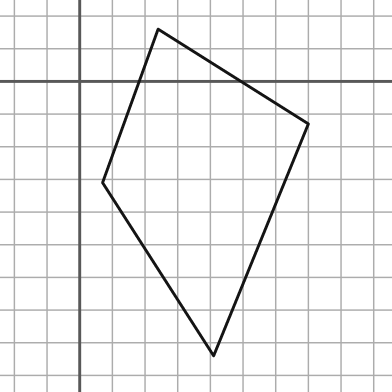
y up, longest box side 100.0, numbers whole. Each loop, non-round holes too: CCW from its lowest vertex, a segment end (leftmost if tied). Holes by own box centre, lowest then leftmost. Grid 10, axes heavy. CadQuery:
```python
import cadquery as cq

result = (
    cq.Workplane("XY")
    .moveTo(41.0, -84.0)
    .lineTo(70.0, -13.0)
    .lineTo(24.0, 16.0)
    .lineTo(7.0, -31.0)
    .close()
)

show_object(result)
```